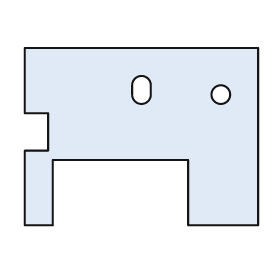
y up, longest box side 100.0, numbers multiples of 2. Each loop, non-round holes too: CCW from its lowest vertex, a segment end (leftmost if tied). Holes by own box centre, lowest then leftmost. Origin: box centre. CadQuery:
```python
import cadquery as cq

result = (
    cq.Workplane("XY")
    .moveTo(-50.0, -38.0)
    .lineTo(-38.0, -38.0)
    .lineTo(-38.0, -10.0)
    .lineTo(20.0, -10.0)
    .lineTo(20.0, -38.0)
    .lineTo(50.0, -38.0)
    .lineTo(50.0, 38.0)
    .lineTo(-50.0, 38.0)
    .lineTo(-50.0, 10.0)
    .lineTo(-40.0, 10.0)
    .lineTo(-40.0, -6.0)
    .lineTo(-50.0, -6.0)
    .close()
    .moveTo(34.0, 18.0)
    .circle(4.0)
    .moveTo(-4.0, 18.0)
    .threePointArc((0.0, 14.0), (4.0, 18.0))
    .lineTo(4.0, 22.0)
    .threePointArc((0.0, 26.0), (-4.0, 22.0))
    .close()
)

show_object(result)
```